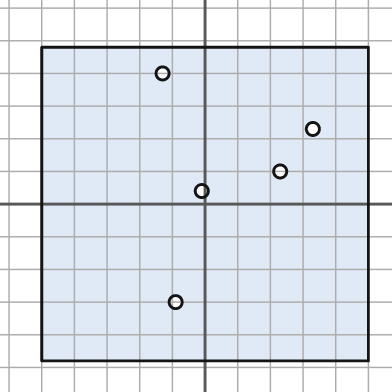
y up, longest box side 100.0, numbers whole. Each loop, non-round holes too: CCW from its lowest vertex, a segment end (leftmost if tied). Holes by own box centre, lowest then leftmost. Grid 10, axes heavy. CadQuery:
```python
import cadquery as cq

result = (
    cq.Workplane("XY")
    .moveTo(-50.0, -48.0)
    .lineTo(50.0, -48.0)
    .lineTo(50.0, 48.0)
    .lineTo(-50.0, 48.0)
    .close()
    .moveTo(-9.0, -30.0)
    .circle(2.0)
    .moveTo(-1.0, 4.0)
    .circle(2.0)
    .moveTo(23.0, 10.0)
    .circle(2.0)
    .moveTo(33.0, 23.0)
    .circle(2.0)
    .moveTo(-13.0, 40.0)
    .circle(2.0)
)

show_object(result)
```